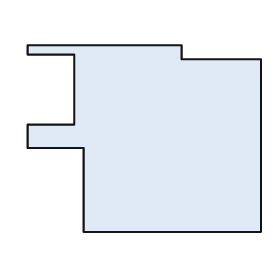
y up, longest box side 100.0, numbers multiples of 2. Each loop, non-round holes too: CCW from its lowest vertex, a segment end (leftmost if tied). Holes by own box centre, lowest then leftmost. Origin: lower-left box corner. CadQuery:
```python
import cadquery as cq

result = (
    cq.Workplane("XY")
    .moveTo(24.0, 0.0)
    .lineTo(100.0, 0.0)
    .lineTo(100.0, 74.0)
    .lineTo(66.0, 74.0)
    .lineTo(66.0, 80.0)
    .lineTo(0.0, 80.0)
    .lineTo(0.0, 76.0)
    .lineTo(20.0, 76.0)
    .lineTo(20.0, 46.0)
    .lineTo(0.0, 46.0)
    .lineTo(0.0, 36.0)
    .lineTo(24.0, 36.0)
    .close()
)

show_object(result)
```